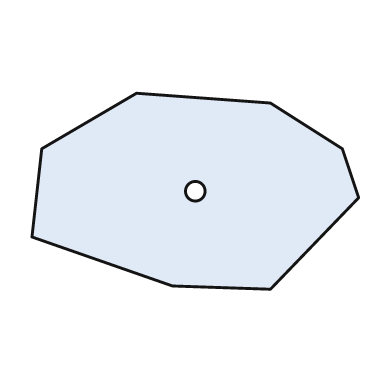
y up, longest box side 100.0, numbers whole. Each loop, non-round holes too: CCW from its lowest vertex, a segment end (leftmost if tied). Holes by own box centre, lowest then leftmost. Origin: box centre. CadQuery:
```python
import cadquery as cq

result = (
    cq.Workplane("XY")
    .moveTo(23.0, -30.0)
    .lineTo(50.0, -2.0)
    .lineTo(45.0, 13.0)
    .lineTo(23.0, 27.0)
    .lineTo(-18.0, 30.0)
    .lineTo(-47.0, 13.0)
    .lineTo(-50.0, -14.0)
    .lineTo(-7.0, -29.0)
    .close()
    .moveTo(0.0, 0.0)
    .circle(3.0)
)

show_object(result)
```